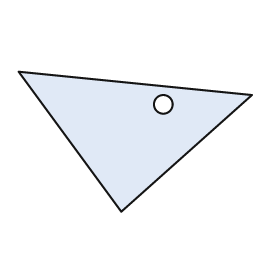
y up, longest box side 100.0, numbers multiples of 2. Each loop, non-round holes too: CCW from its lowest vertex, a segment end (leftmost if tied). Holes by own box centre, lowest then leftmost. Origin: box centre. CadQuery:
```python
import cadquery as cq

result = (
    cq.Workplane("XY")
    .moveTo(-6.0, -30.0)
    .lineTo(50.0, 20.0)
    .lineTo(-50.0, 30.0)
    .close()
    .moveTo(12.0, 16.0)
    .circle(4.0)
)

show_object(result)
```